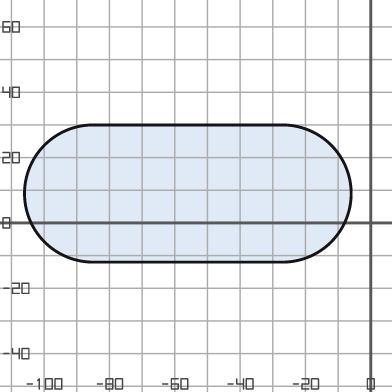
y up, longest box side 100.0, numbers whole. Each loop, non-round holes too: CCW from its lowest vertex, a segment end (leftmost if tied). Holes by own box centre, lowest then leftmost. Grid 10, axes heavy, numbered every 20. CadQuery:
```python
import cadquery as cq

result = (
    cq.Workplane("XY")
    .moveTo(-85.0, -12.0)
    .lineTo(-27.0, -12.0)
    .threePointArc((-6.0, 9.0), (-27.0, 30.0))
    .lineTo(-85.0, 30.0)
    .threePointArc((-106.0, 9.0), (-85.0, -12.0))
    .close()
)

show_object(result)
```